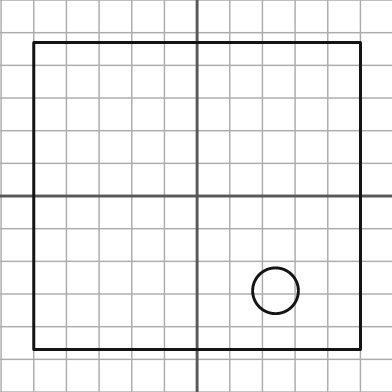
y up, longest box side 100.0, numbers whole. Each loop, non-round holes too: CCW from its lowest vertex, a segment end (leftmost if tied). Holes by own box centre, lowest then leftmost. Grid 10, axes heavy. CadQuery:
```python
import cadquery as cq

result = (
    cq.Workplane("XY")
    .moveTo(-50.0, -47.0)
    .lineTo(50.0, -47.0)
    .lineTo(50.0, 47.0)
    .lineTo(-50.0, 47.0)
    .close()
    .moveTo(24.0, -29.0)
    .circle(7.0)
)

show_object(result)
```